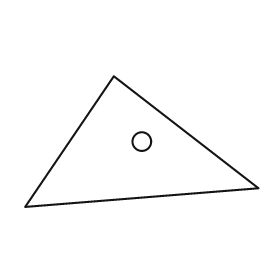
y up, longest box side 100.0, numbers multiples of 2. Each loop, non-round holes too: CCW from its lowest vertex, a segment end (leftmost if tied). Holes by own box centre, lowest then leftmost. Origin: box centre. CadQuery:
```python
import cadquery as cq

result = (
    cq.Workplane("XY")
    .moveTo(-50.0, -28.0)
    .lineTo(50.0, -20.0)
    .lineTo(-12.0, 28.0)
    .close()
    .moveTo(0.0, 0.0)
    .circle(4.0)
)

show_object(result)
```